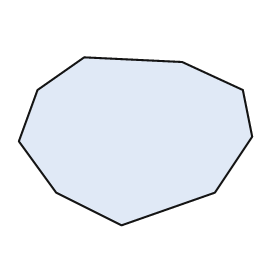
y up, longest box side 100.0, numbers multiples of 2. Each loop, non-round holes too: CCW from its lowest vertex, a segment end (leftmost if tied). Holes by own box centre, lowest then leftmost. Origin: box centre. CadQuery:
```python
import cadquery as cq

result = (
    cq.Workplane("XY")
    .moveTo(-6.0, -36.0)
    .lineTo(34.0, -22.0)
    .lineTo(50.0, 2.0)
    .lineTo(46.0, 22.0)
    .lineTo(20.0, 34.0)
    .lineTo(-22.0, 36.0)
    .lineTo(-42.0, 22.0)
    .lineTo(-50.0, 0.0)
    .lineTo(-34.0, -22.0)
    .close()
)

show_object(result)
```